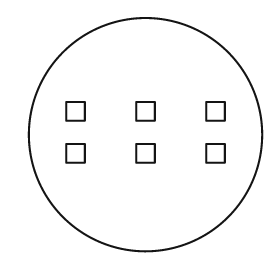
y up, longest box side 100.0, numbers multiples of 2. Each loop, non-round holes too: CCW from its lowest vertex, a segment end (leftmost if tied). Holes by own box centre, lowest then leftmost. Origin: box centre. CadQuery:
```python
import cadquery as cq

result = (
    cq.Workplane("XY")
    .moveTo(0.0, 0.0)
    .circle(50.0)
    .moveTo(-34.0, -12.0)
    .lineTo(-26.0, -12.0)
    .lineTo(-26.0, -4.0)
    .lineTo(-34.0, -4.0)
    .close()
    .moveTo(-4.0, -12.0)
    .lineTo(4.0, -12.0)
    .lineTo(4.0, -4.0)
    .lineTo(-4.0, -4.0)
    .close()
    .moveTo(26.0, -12.0)
    .lineTo(34.0, -12.0)
    .lineTo(34.0, -4.0)
    .lineTo(26.0, -4.0)
    .close()
    .moveTo(-34.0, 6.0)
    .lineTo(-26.0, 6.0)
    .lineTo(-26.0, 14.0)
    .lineTo(-34.0, 14.0)
    .close()
    .moveTo(-4.0, 6.0)
    .lineTo(4.0, 6.0)
    .lineTo(4.0, 14.0)
    .lineTo(-4.0, 14.0)
    .close()
    .moveTo(26.0, 6.0)
    .lineTo(34.0, 6.0)
    .lineTo(34.0, 14.0)
    .lineTo(26.0, 14.0)
    .close()
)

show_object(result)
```